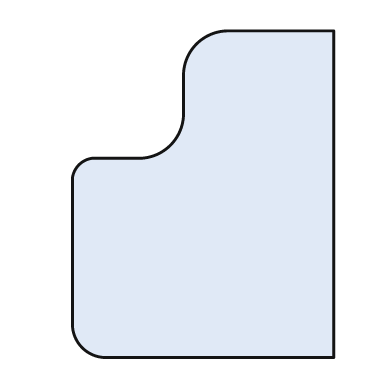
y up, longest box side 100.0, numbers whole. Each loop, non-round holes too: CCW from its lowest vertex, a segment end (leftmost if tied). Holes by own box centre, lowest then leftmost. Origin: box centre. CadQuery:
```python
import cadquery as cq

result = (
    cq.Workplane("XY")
    .moveTo(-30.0, -50.0)
    .lineTo(40.0, -50.0)
    .lineTo(40.0, 50.0)
    .lineTo(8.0, 50.0)
    .threePointArc((-2.0, 46.0), (-6.0, 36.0))
    .lineTo(-6.0, 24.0)
    .threePointArc((-10.0, 15.0), (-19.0, 11.0))
    .lineTo(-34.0, 11.0)
    .threePointArc((-38.0, 9.0), (-40.0, 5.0))
    .lineTo(-40.0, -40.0)
    .threePointArc((-37.0, -47.0), (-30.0, -50.0))
    .close()
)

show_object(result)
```